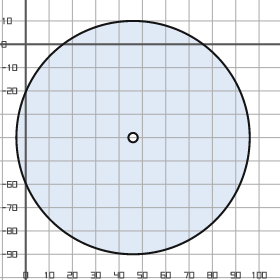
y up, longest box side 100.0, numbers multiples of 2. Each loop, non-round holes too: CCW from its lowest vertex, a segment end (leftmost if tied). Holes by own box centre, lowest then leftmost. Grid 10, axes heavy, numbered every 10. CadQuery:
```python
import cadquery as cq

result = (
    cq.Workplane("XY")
    .moveTo(46.0, -40.0)
    .circle(50.0)
    .moveTo(46.0, -40.0)
    .circle(2.0)
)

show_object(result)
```